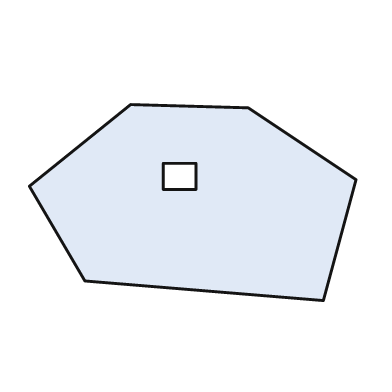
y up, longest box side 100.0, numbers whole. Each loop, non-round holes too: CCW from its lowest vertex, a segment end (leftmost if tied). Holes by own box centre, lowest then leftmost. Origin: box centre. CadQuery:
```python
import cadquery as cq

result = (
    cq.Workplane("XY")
    .moveTo(40.0, -30.0)
    .lineTo(50.0, 7.0)
    .lineTo(17.0, 29.0)
    .lineTo(-19.0, 30.0)
    .lineTo(-50.0, 5.0)
    .lineTo(-33.0, -24.0)
    .close()
    .moveTo(-9.0, 4.0)
    .lineTo(1.0, 4.0)
    .lineTo(1.0, 12.0)
    .lineTo(-9.0, 12.0)
    .close()
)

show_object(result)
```